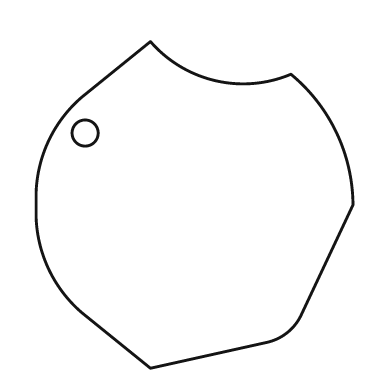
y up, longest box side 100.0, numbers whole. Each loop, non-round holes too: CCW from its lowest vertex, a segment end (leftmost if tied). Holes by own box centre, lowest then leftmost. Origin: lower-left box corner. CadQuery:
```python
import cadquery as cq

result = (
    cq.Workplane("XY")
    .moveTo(35.0, 0.0)
    .lineTo(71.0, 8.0)
    .threePointArc((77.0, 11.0), (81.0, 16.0))
    .lineTo(97.0, 50.0)
    .threePointArc((92.0, 72.0), (78.0, 90.0))
    .threePointArc((55.0, 88.0), (35.0, 100.0))
    .lineTo(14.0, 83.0)
    .threePointArc((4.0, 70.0), (0.0, 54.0))
    .lineTo(0.0, 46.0)
    .threePointArc((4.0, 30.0), (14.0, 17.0))
    .close()
    .moveTo(15.0, 72.0)
    .circle(4.0)
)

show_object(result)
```